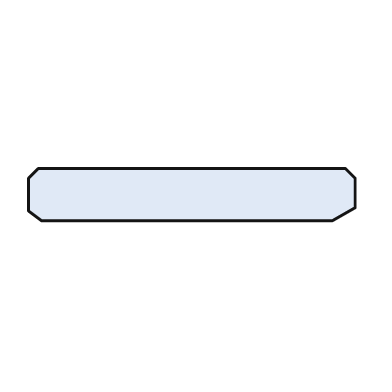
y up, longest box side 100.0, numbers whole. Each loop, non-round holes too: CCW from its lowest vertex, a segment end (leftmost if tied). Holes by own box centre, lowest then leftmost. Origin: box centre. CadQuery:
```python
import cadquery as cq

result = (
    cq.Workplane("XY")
    .moveTo(-46.0, -8.0)
    .lineTo(43.0, -8.0)
    .lineTo(50.0, -4.0)
    .lineTo(50.0, 5.0)
    .lineTo(47.0, 8.0)
    .lineTo(-47.0, 8.0)
    .lineTo(-50.0, 5.0)
    .lineTo(-50.0, -5.0)
    .close()
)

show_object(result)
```